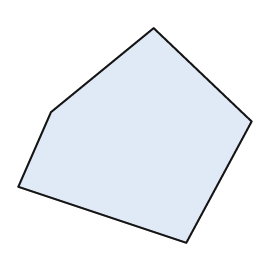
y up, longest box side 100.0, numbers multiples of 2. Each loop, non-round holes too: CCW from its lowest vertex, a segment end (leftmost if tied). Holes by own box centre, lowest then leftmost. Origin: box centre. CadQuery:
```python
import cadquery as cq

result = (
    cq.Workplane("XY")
    .moveTo(22.0, -46.0)
    .lineTo(50.0, 6.0)
    .lineTo(8.0, 46.0)
    .lineTo(-36.0, 10.0)
    .lineTo(-50.0, -22.0)
    .close()
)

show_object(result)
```